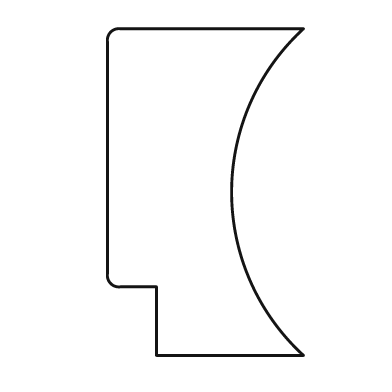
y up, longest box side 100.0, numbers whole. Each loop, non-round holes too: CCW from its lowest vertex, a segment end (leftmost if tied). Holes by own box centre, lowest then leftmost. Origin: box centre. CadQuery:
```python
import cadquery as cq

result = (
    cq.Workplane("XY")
    .moveTo(-15.0, -50.0)
    .lineTo(30.0, -50.0)
    .threePointArc((8.0, 0.0), (30.0, 50.0))
    .lineTo(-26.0, 50.0)
    .threePointArc((-29.0, 49.0), (-30.0, 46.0))
    .lineTo(-30.0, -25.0)
    .threePointArc((-29.0, -28.0), (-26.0, -29.0))
    .lineTo(-15.0, -29.0)
    .close()
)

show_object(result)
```